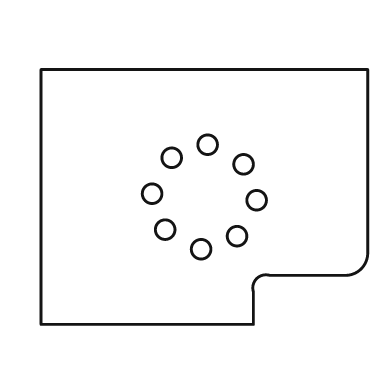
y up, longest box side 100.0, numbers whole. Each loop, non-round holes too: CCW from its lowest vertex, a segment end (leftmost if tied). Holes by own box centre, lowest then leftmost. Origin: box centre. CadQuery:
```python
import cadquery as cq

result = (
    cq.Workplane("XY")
    .moveTo(-50.0, -39.0)
    .lineTo(15.0, -39.0)
    .lineTo(15.0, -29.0)
    .threePointArc((16.0, -25.0), (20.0, -24.0))
    .lineTo(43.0, -24.0)
    .threePointArc((48.0, -22.0), (50.0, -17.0))
    .lineTo(50.0, 39.0)
    .lineTo(-50.0, 39.0)
    .close()
    .moveTo(-1.0, -16.0)
    .circle(3.0)
    .moveTo(10.0, -12.0)
    .circle(3.0)
    .moveTo(-12.0, -10.0)
    .circle(3.0)
    .moveTo(16.0, -1.0)
    .circle(3.0)
    .moveTo(-16.0, 1.0)
    .circle(3.0)
    .moveTo(12.0, 10.0)
    .circle(3.0)
    .moveTo(-10.0, 12.0)
    .circle(3.0)
    .moveTo(1.0, 16.0)
    .circle(3.0)
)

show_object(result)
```